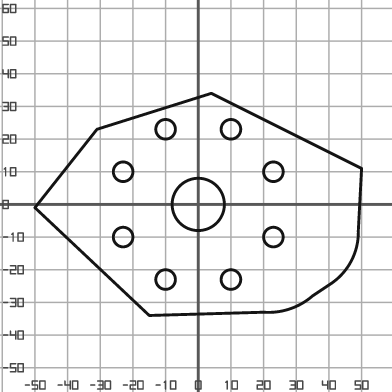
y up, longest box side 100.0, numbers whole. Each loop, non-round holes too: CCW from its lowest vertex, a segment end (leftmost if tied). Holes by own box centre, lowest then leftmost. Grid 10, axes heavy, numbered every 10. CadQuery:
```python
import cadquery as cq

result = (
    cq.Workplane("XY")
    .moveTo(-15.0, -34.0)
    .lineTo(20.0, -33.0)
    .threePointArc((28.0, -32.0), (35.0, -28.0))
    .lineTo(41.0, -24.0)
    .threePointArc((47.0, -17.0), (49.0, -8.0))
    .lineTo(50.0, 11.0)
    .lineTo(4.0, 34.0)
    .lineTo(-31.0, 23.0)
    .lineTo(-50.0, -1.0)
    .close()
    .moveTo(-10.0, -23.0)
    .circle(3.0)
    .moveTo(10.0, -23.0)
    .circle(3.0)
    .moveTo(-23.0, -10.0)
    .circle(3.0)
    .moveTo(23.0, -10.0)
    .circle(3.0)
    .moveTo(0.0, 0.0)
    .circle(8.0)
    .moveTo(-23.0, 10.0)
    .circle(3.0)
    .moveTo(23.0, 10.0)
    .circle(3.0)
    .moveTo(-10.0, 23.0)
    .circle(3.0)
    .moveTo(10.0, 23.0)
    .circle(3.0)
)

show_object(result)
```